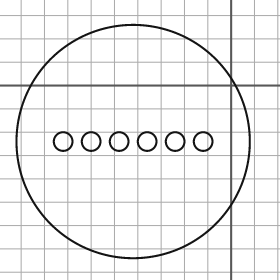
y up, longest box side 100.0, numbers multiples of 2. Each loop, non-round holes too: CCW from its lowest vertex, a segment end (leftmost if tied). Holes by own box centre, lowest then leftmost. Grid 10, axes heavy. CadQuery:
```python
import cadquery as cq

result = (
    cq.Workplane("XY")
    .moveTo(-42.0, -24.0)
    .circle(50.0)
    .moveTo(-72.0, -24.0)
    .circle(4.0)
    .moveTo(-60.0, -24.0)
    .circle(4.0)
    .moveTo(-48.0, -24.0)
    .circle(4.0)
    .moveTo(-36.0, -24.0)
    .circle(4.0)
    .moveTo(-24.0, -24.0)
    .circle(4.0)
    .moveTo(-12.0, -24.0)
    .circle(4.0)
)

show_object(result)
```